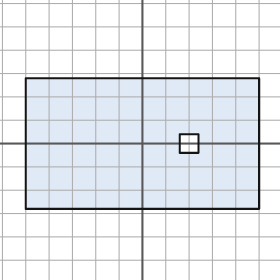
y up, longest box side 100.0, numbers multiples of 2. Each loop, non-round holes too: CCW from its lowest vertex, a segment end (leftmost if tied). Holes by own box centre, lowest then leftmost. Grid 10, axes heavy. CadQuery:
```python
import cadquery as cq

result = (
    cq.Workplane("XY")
    .moveTo(-50.0, -28.0)
    .lineTo(50.0, -28.0)
    .lineTo(50.0, 28.0)
    .lineTo(-50.0, 28.0)
    .close()
    .moveTo(16.0, -4.0)
    .lineTo(24.0, -4.0)
    .lineTo(24.0, 4.0)
    .lineTo(16.0, 4.0)
    .close()
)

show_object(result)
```